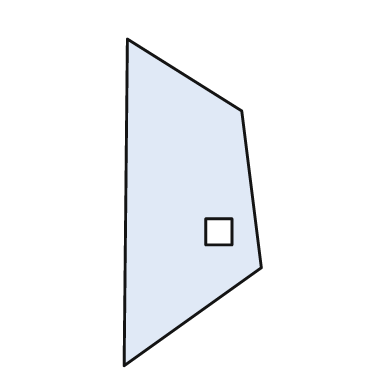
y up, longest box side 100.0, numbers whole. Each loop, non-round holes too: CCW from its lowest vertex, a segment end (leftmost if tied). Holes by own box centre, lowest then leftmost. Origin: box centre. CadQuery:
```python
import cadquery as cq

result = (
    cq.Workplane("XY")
    .moveTo(-21.0, -50.0)
    .lineTo(21.0, -20.0)
    .lineTo(15.0, 28.0)
    .lineTo(-20.0, 50.0)
    .close()
    .moveTo(4.0, -13.0)
    .lineTo(12.0, -13.0)
    .lineTo(12.0, -5.0)
    .lineTo(4.0, -5.0)
    .close()
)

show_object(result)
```